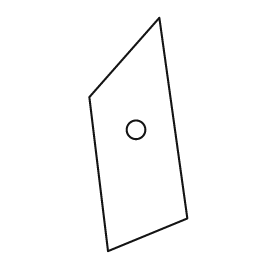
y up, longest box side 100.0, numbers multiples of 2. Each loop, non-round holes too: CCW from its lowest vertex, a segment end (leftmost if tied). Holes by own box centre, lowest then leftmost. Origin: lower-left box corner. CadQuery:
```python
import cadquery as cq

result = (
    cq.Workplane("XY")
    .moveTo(8.0, 0.0)
    .lineTo(42.0, 14.0)
    .lineTo(30.0, 100.0)
    .lineTo(0.0, 66.0)
    .close()
    .moveTo(20.0, 52.0)
    .circle(4.0)
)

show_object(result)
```